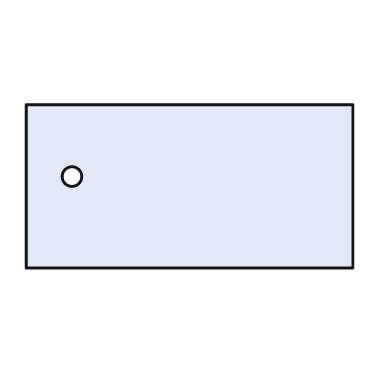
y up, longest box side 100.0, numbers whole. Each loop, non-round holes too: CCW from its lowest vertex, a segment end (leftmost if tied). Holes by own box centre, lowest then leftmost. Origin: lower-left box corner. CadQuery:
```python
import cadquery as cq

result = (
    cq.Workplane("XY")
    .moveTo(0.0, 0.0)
    .lineTo(100.0, 0.0)
    .lineTo(100.0, 50.0)
    .lineTo(0.0, 50.0)
    .close()
    .moveTo(14.0, 28.0)
    .circle(3.0)
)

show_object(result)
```